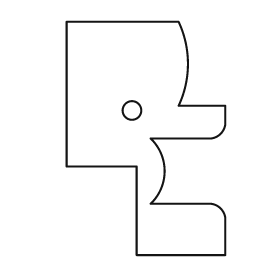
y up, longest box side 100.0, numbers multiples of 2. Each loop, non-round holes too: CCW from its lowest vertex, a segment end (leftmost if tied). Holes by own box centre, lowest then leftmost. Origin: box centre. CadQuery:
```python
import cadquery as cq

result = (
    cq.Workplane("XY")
    .moveTo(-4.0, -50.0)
    .lineTo(34.0, -50.0)
    .lineTo(34.0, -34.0)
    .threePointArc((32.0, -30.0), (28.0, -28.0))
    .lineTo(2.0, -28.0)
    .threePointArc((8.0, -14.0), (2.0, 0.0))
    .lineTo(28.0, 0.0)
    .threePointArc((32.0, 2.0), (34.0, 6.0))
    .lineTo(34.0, 14.0)
    .lineTo(14.0, 14.0)
    .threePointArc((18.0, 32.0), (14.0, 50.0))
    .lineTo(-34.0, 50.0)
    .lineTo(-34.0, -12.0)
    .lineTo(-4.0, -12.0)
    .close()
    .moveTo(-6.0, 12.0)
    .circle(4.0)
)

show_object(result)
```